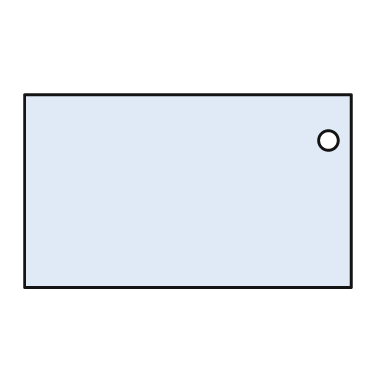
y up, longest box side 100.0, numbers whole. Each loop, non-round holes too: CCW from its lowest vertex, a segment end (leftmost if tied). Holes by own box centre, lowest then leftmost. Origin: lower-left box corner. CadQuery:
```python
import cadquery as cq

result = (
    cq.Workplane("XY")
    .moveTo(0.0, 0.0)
    .lineTo(100.0, 0.0)
    .lineTo(100.0, 59.0)
    .lineTo(0.0, 59.0)
    .close()
    .moveTo(93.0, 45.0)
    .circle(3.0)
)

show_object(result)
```